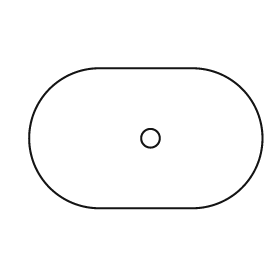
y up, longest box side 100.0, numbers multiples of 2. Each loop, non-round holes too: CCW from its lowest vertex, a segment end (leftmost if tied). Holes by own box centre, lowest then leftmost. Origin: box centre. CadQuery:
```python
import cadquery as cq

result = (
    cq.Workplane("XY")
    .moveTo(-20.0, -30.0)
    .lineTo(20.0, -30.0)
    .threePointArc((50.0, 0.0), (20.0, 30.0))
    .lineTo(-20.0, 30.0)
    .threePointArc((-50.0, 0.0), (-20.0, -30.0))
    .close()
    .moveTo(2.0, 0.0)
    .circle(4.0)
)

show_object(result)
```